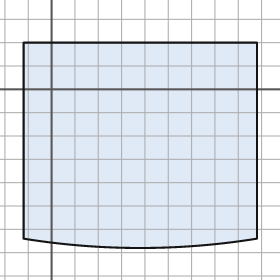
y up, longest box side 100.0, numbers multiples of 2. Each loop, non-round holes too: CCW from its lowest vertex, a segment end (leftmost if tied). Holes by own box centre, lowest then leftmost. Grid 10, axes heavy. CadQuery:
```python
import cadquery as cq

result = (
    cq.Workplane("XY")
    .moveTo(-12.0, -64.0)
    .threePointArc((38.0, -68.0), (88.0, -64.0))
    .lineTo(88.0, 20.0)
    .lineTo(-12.0, 20.0)
    .close()
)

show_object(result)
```